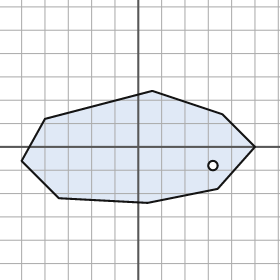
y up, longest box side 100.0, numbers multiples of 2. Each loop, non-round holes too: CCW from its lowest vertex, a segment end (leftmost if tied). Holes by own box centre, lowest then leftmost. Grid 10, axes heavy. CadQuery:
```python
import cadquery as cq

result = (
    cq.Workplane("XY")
    .moveTo(4.0, -24.0)
    .lineTo(34.0, -18.0)
    .lineTo(50.0, 0.0)
    .lineTo(36.0, 14.0)
    .lineTo(6.0, 24.0)
    .lineTo(-40.0, 12.0)
    .lineTo(-50.0, -6.0)
    .lineTo(-34.0, -22.0)
    .close()
    .moveTo(32.0, -8.0)
    .circle(2.0)
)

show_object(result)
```